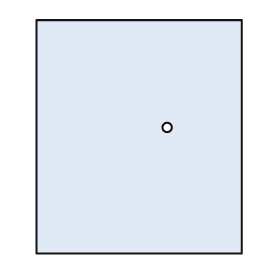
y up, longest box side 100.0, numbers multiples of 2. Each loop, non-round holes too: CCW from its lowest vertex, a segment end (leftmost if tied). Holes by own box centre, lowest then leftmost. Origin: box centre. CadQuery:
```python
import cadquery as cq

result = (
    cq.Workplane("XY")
    .moveTo(-44.0, -50.0)
    .lineTo(44.0, -50.0)
    .lineTo(44.0, 50.0)
    .lineTo(-44.0, 50.0)
    .close()
    .moveTo(12.0, 4.0)
    .circle(2.0)
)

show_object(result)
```